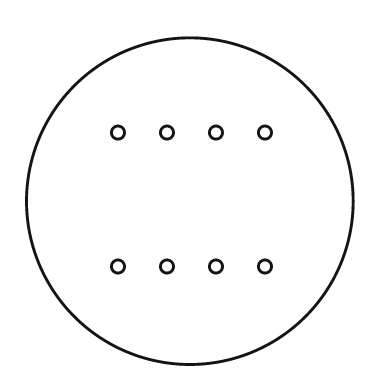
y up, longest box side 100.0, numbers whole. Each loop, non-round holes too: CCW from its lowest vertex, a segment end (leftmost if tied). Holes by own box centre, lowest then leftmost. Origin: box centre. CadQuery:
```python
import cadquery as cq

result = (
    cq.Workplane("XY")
    .moveTo(0.0, 0.0)
    .circle(50.0)
    .moveTo(-22.0, -20.0)
    .circle(2.0)
    .moveTo(-7.0, -20.0)
    .circle(2.0)
    .moveTo(8.0, -20.0)
    .circle(2.0)
    .moveTo(23.0, -20.0)
    .circle(2.0)
    .moveTo(-22.0, 21.0)
    .circle(2.0)
    .moveTo(-7.0, 21.0)
    .circle(2.0)
    .moveTo(8.0, 21.0)
    .circle(2.0)
    .moveTo(23.0, 21.0)
    .circle(2.0)
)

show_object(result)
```